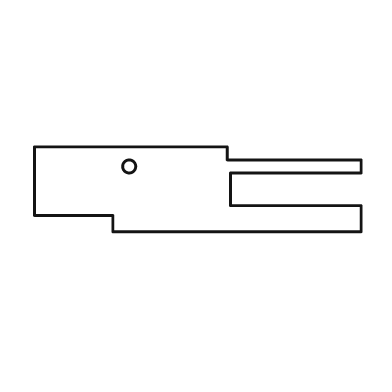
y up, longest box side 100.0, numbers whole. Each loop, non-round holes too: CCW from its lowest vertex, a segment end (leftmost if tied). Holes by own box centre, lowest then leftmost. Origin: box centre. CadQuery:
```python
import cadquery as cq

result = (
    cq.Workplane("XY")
    .moveTo(-26.0, -13.0)
    .lineTo(50.0, -13.0)
    .lineTo(50.0, -5.0)
    .lineTo(10.0, -5.0)
    .lineTo(10.0, 5.0)
    .lineTo(50.0, 5.0)
    .lineTo(50.0, 9.0)
    .lineTo(9.0, 9.0)
    .lineTo(9.0, 13.0)
    .lineTo(-50.0, 13.0)
    .lineTo(-50.0, -8.0)
    .lineTo(-26.0, -8.0)
    .close()
    .moveTo(-21.0, 7.0)
    .circle(2.0)
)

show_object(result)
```